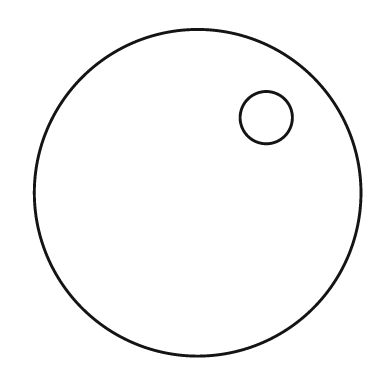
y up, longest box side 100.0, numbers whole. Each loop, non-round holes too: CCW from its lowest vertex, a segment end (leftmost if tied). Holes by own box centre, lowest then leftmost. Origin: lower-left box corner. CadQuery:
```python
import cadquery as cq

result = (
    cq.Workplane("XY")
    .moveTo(50.0, 50.0)
    .circle(50.0)
    .moveTo(71.0, 73.0)
    .circle(8.0)
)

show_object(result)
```